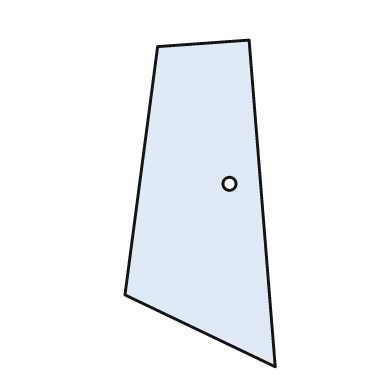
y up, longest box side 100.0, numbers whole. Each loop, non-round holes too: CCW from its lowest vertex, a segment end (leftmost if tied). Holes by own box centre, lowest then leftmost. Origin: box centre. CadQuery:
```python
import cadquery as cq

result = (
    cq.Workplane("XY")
    .moveTo(23.0, -50.0)
    .lineTo(15.0, 50.0)
    .lineTo(-13.0, 48.0)
    .lineTo(-23.0, -28.0)
    .close()
    .moveTo(9.0, 6.0)
    .circle(2.0)
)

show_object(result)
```